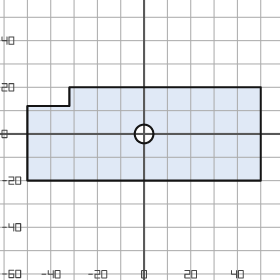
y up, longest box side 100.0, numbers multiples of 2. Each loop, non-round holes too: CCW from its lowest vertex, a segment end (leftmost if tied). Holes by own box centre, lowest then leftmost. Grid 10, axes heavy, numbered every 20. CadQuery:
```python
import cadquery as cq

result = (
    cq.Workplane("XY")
    .moveTo(-50.0, -20.0)
    .lineTo(50.0, -20.0)
    .lineTo(50.0, 20.0)
    .lineTo(-32.0, 20.0)
    .lineTo(-32.0, 12.0)
    .lineTo(-50.0, 12.0)
    .close()
    .moveTo(0.0, 0.0)
    .circle(4.0)
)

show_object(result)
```